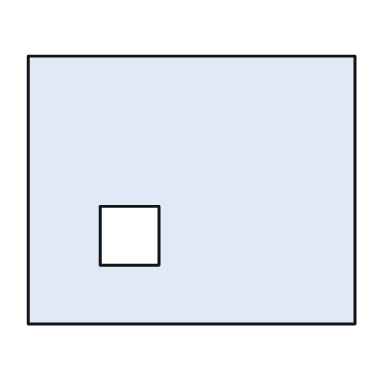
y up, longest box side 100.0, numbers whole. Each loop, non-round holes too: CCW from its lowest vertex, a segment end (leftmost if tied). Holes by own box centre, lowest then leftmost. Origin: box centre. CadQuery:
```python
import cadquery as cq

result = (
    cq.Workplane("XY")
    .moveTo(-50.0, -41.0)
    .lineTo(50.0, -41.0)
    .lineTo(50.0, 41.0)
    .lineTo(-50.0, 41.0)
    .close()
    .moveTo(-28.0, -23.0)
    .lineTo(-10.0, -23.0)
    .lineTo(-10.0, -5.0)
    .lineTo(-28.0, -5.0)
    .close()
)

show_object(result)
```